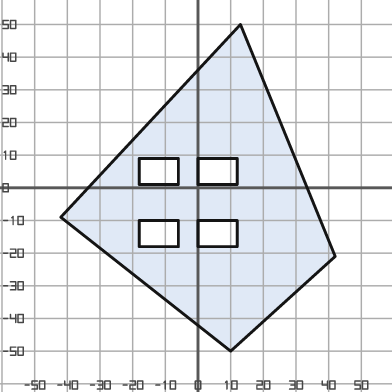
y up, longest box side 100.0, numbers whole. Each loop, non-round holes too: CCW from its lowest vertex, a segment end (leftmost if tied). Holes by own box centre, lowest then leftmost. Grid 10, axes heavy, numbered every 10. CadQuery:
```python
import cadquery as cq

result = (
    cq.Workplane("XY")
    .moveTo(10.0, -50.0)
    .lineTo(42.0, -21.0)
    .lineTo(13.0, 50.0)
    .lineTo(-42.0, -9.0)
    .close()
    .moveTo(-18.0, -18.0)
    .lineTo(-6.0, -18.0)
    .lineTo(-6.0, -10.0)
    .lineTo(-18.0, -10.0)
    .close()
    .moveTo(0.0, -18.0)
    .lineTo(12.0, -18.0)
    .lineTo(12.0, -10.0)
    .lineTo(0.0, -10.0)
    .close()
    .moveTo(-18.0, 1.0)
    .lineTo(-6.0, 1.0)
    .lineTo(-6.0, 9.0)
    .lineTo(-18.0, 9.0)
    .close()
    .moveTo(0.0, 1.0)
    .lineTo(12.0, 1.0)
    .lineTo(12.0, 9.0)
    .lineTo(0.0, 9.0)
    .close()
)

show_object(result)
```